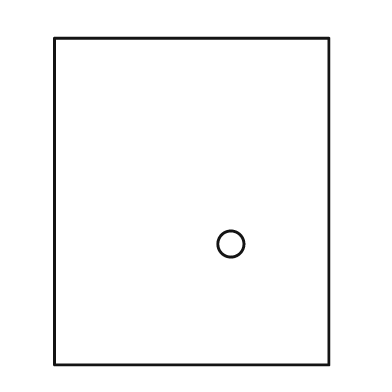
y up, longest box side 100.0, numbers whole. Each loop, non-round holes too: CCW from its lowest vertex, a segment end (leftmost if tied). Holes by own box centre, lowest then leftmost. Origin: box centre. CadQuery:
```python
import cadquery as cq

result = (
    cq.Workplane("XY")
    .moveTo(-42.0, -50.0)
    .lineTo(42.0, -50.0)
    .lineTo(42.0, 50.0)
    .lineTo(-42.0, 50.0)
    .close()
    .moveTo(12.0, -13.0)
    .circle(4.0)
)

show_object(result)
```